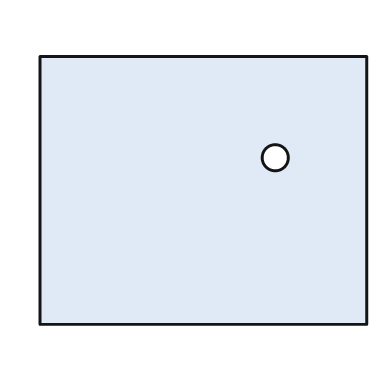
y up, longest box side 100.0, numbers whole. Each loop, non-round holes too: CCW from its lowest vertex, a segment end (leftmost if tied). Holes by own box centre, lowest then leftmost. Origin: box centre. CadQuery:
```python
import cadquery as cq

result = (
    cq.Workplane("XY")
    .moveTo(-50.0, -41.0)
    .lineTo(50.0, -41.0)
    .lineTo(50.0, 41.0)
    .lineTo(-50.0, 41.0)
    .close()
    .moveTo(22.0, 10.0)
    .circle(4.0)
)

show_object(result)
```